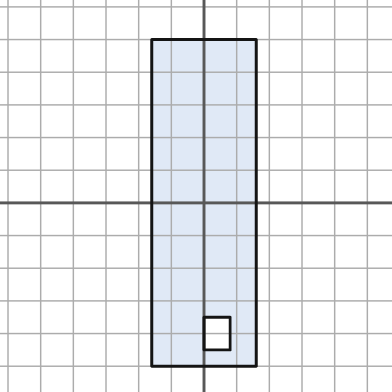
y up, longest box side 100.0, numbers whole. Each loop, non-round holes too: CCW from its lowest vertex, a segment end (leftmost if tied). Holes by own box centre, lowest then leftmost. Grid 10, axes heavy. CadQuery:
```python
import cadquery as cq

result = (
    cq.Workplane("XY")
    .moveTo(-16.0, -50.0)
    .lineTo(16.0, -50.0)
    .lineTo(16.0, 50.0)
    .lineTo(-16.0, 50.0)
    .close()
    .moveTo(0.0, -45.0)
    .lineTo(8.0, -45.0)
    .lineTo(8.0, -35.0)
    .lineTo(0.0, -35.0)
    .close()
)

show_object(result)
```